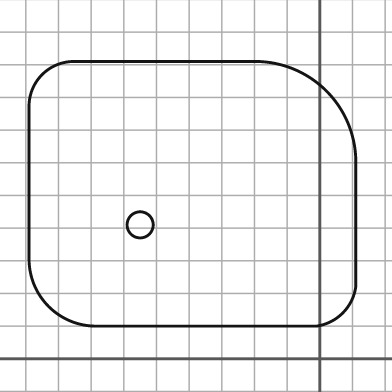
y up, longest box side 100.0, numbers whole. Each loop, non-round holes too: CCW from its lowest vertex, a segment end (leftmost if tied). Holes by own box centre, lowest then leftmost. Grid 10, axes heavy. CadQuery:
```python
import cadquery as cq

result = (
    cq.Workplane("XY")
    .moveTo(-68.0, 10.0)
    .lineTo(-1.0, 10.0)
    .threePointArc((7.0, 14.0), (11.0, 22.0))
    .lineTo(11.0, 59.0)
    .threePointArc((2.0, 82.0), (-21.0, 91.0))
    .lineTo(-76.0, 91.0)
    .threePointArc((-85.0, 87.0), (-89.0, 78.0))
    .lineTo(-89.0, 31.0)
    .threePointArc((-83.0, 16.0), (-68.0, 10.0))
    .close()
    .moveTo(-55.0, 41.0)
    .circle(4.0)
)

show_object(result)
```